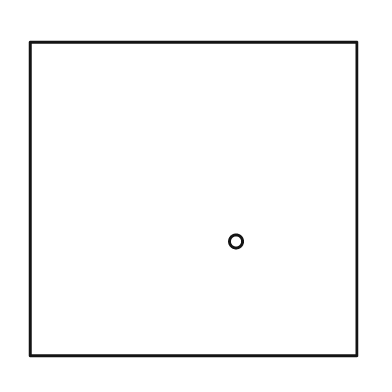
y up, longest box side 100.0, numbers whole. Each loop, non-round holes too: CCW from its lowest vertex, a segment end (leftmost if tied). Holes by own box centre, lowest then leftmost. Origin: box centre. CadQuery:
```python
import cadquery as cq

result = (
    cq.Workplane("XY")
    .moveTo(-50.0, -48.0)
    .lineTo(50.0, -48.0)
    .lineTo(50.0, 48.0)
    .lineTo(-50.0, 48.0)
    .close()
    .moveTo(13.0, -13.0)
    .circle(2.0)
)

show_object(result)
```